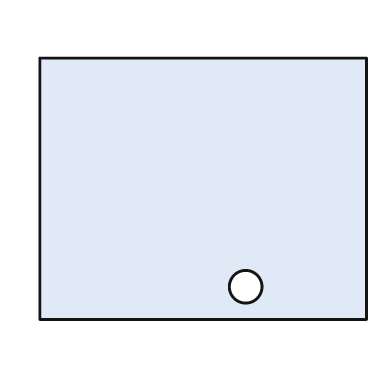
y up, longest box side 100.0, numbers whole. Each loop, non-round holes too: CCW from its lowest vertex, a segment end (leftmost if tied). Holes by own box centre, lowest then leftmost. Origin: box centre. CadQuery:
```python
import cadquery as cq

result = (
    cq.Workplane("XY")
    .moveTo(-50.0, -40.0)
    .lineTo(50.0, -40.0)
    .lineTo(50.0, 40.0)
    .lineTo(-50.0, 40.0)
    .close()
    .moveTo(13.0, -30.0)
    .circle(5.0)
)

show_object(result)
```